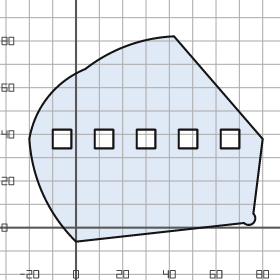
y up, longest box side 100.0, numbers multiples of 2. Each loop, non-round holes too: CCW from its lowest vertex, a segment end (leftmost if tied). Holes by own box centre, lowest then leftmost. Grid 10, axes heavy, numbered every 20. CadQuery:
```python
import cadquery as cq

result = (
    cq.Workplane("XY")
    .moveTo(0.0, -6.0)
    .lineTo(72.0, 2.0)
    .threePointArc((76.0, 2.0), (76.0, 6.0))
    .lineTo(80.0, 38.0)
    .lineTo(42.0, 82.0)
    .threePointArc((22.0, 78.0), (4.0, 68.0))
    .threePointArc((-12.0, 56.0), (-20.0, 38.0))
    .threePointArc((-14.0, 14.0), (0.0, -6.0))
    .close()
    .moveTo(-10.0, 34.0)
    .lineTo(-2.0, 34.0)
    .lineTo(-2.0, 42.0)
    .lineTo(-10.0, 42.0)
    .close()
    .moveTo(8.0, 34.0)
    .lineTo(16.0, 34.0)
    .lineTo(16.0, 42.0)
    .lineTo(8.0, 42.0)
    .close()
    .moveTo(26.0, 34.0)
    .lineTo(34.0, 34.0)
    .lineTo(34.0, 42.0)
    .lineTo(26.0, 42.0)
    .close()
    .moveTo(44.0, 34.0)
    .lineTo(52.0, 34.0)
    .lineTo(52.0, 42.0)
    .lineTo(44.0, 42.0)
    .close()
    .moveTo(62.0, 34.0)
    .lineTo(70.0, 34.0)
    .lineTo(70.0, 42.0)
    .lineTo(62.0, 42.0)
    .close()
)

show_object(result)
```